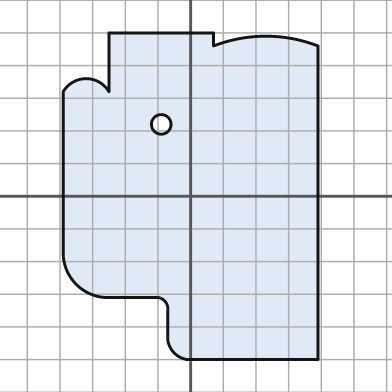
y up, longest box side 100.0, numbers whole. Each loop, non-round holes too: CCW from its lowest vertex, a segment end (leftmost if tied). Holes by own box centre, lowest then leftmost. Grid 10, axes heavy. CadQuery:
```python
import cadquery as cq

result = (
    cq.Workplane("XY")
    .moveTo(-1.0, -50.0)
    .lineTo(39.0, -50.0)
    .lineTo(39.0, 46.0)
    .threePointArc((23.0, 49.0), (7.0, 46.0))
    .lineTo(7.0, 50.0)
    .lineTo(-25.0, 50.0)
    .lineTo(-25.0, 32.0)
    .threePointArc((-32.0, 36.0), (-39.0, 32.0))
    .lineTo(-39.0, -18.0)
    .threePointArc((-35.0, -27.0), (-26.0, -31.0))
    .lineTo(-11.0, -31.0)
    .threePointArc((-8.0, -32.0), (-7.0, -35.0))
    .lineTo(-7.0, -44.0)
    .threePointArc((-5.0, -48.0), (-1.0, -50.0))
    .close()
    .moveTo(-9.0, 22.0)
    .circle(3.0)
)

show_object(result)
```